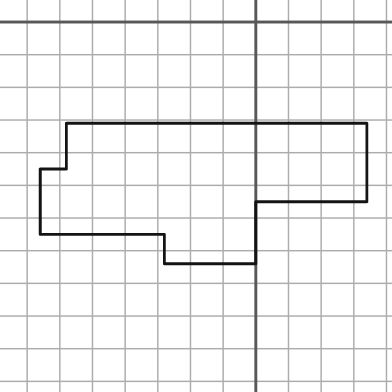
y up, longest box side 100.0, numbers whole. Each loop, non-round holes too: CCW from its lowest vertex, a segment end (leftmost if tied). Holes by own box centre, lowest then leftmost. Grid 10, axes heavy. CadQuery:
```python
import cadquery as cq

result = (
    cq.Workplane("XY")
    .moveTo(-28.0, -74.0)
    .lineTo(0.0, -74.0)
    .lineTo(0.0, -55.0)
    .lineTo(34.0, -55.0)
    .lineTo(34.0, -31.0)
    .lineTo(-58.0, -31.0)
    .lineTo(-58.0, -45.0)
    .lineTo(-66.0, -45.0)
    .lineTo(-66.0, -65.0)
    .lineTo(-28.0, -65.0)
    .close()
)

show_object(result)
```